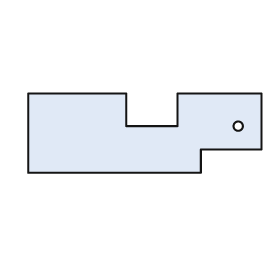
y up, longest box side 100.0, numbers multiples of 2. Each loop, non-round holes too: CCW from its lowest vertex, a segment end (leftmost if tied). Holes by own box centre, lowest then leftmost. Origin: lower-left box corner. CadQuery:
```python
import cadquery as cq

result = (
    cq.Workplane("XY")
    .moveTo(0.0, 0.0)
    .lineTo(74.0, 0.0)
    .lineTo(74.0, 10.0)
    .lineTo(100.0, 10.0)
    .lineTo(100.0, 34.0)
    .lineTo(64.0, 34.0)
    .lineTo(64.0, 20.0)
    .lineTo(42.0, 20.0)
    .lineTo(42.0, 34.0)
    .lineTo(0.0, 34.0)
    .close()
    .moveTo(90.0, 20.0)
    .circle(2.0)
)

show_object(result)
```